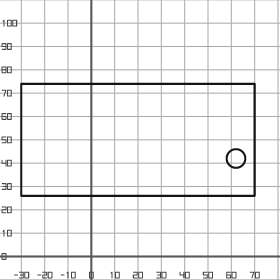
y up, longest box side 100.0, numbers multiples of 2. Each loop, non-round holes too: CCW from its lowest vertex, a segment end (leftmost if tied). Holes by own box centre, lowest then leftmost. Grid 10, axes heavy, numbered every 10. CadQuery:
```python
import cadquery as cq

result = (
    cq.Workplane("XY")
    .moveTo(-30.0, 26.0)
    .lineTo(70.0, 26.0)
    .lineTo(70.0, 74.0)
    .lineTo(-30.0, 74.0)
    .close()
    .moveTo(62.0, 42.0)
    .circle(4.0)
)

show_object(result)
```